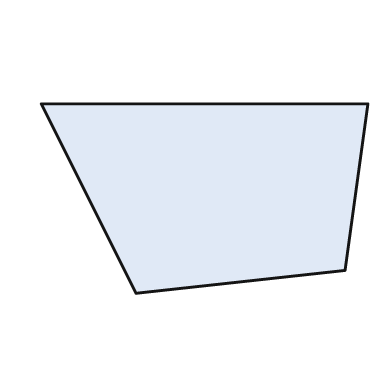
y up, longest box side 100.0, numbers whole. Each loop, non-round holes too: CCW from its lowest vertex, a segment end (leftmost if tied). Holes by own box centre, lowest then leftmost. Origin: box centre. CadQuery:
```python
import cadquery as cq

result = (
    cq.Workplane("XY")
    .moveTo(-21.0, -29.0)
    .lineTo(43.0, -22.0)
    .lineTo(50.0, 29.0)
    .lineTo(-50.0, 29.0)
    .close()
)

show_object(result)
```